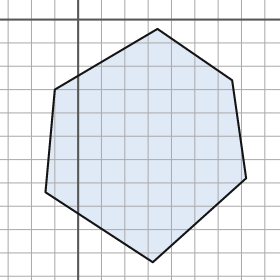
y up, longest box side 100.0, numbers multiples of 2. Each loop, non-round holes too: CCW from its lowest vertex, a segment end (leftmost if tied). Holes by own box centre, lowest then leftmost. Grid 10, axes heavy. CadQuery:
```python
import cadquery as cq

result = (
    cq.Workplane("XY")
    .moveTo(32.0, -104.0)
    .lineTo(72.0, -68.0)
    .lineTo(66.0, -26.0)
    .lineTo(34.0, -4.0)
    .lineTo(-10.0, -30.0)
    .lineTo(-14.0, -74.0)
    .close()
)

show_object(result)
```